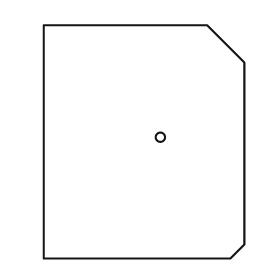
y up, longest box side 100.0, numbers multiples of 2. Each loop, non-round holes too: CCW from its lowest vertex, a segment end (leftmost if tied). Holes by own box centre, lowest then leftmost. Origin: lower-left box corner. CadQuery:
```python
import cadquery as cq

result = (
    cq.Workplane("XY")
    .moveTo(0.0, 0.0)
    .lineTo(80.0, 0.0)
    .lineTo(86.0, 6.0)
    .lineTo(86.0, 84.0)
    .lineTo(70.0, 100.0)
    .lineTo(0.0, 100.0)
    .close()
    .moveTo(50.0, 52.0)
    .circle(2.0)
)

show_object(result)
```